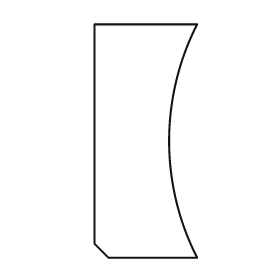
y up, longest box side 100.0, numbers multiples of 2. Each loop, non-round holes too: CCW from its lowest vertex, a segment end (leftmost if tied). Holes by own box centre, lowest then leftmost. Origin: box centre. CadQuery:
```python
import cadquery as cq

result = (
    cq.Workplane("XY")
    .moveTo(-16.0, -50.0)
    .lineTo(22.0, -50.0)
    .threePointArc((10.0, 0.0), (22.0, 50.0))
    .lineTo(-22.0, 50.0)
    .lineTo(-22.0, -44.0)
    .close()
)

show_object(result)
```